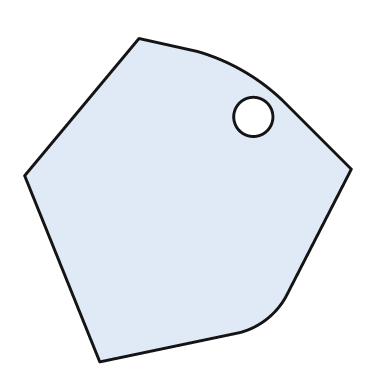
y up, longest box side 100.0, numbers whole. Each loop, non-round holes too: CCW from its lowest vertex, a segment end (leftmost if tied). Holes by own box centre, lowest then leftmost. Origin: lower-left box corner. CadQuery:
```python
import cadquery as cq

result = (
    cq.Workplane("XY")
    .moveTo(23.0, 0.0)
    .lineTo(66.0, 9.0)
    .threePointArc((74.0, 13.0), (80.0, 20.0))
    .lineTo(100.0, 59.0)
    .lineTo(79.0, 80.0)
    .threePointArc((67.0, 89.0), (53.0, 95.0))
    .lineTo(35.0, 99.0)
    .lineTo(0.0, 57.0)
    .close()
    .moveTo(70.0, 75.0)
    .circle(6.0)
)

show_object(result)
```